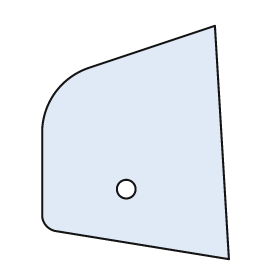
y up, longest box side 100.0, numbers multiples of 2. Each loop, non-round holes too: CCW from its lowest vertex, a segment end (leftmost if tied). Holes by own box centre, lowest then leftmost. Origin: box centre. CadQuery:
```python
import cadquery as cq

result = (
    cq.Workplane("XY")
    .moveTo(40.0, -50.0)
    .lineTo(34.0, 50.0)
    .lineTo(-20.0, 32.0)
    .threePointArc((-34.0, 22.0), (-40.0, 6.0))
    .lineTo(-40.0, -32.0)
    .threePointArc((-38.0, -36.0), (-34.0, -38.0))
    .close()
    .moveTo(-4.0, -20.0)
    .circle(4.0)
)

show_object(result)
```